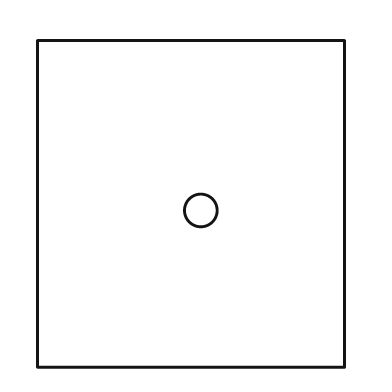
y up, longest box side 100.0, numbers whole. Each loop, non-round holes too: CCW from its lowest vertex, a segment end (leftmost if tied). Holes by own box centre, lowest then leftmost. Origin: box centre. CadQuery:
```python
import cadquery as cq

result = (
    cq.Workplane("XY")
    .moveTo(-47.0, -50.0)
    .lineTo(47.0, -50.0)
    .lineTo(47.0, 50.0)
    .lineTo(-47.0, 50.0)
    .close()
    .moveTo(3.0, -2.0)
    .circle(5.0)
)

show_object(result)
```